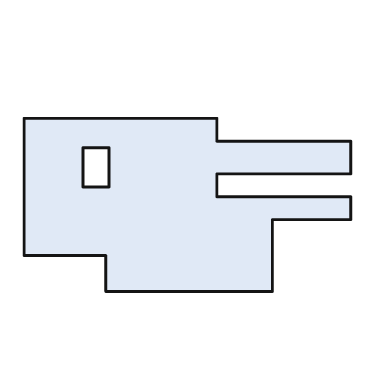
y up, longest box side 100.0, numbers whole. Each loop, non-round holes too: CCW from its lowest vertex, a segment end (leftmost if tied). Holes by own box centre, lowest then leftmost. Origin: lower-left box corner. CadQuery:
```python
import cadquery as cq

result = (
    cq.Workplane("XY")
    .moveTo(25.0, 0.0)
    .lineTo(76.0, 0.0)
    .lineTo(76.0, 22.0)
    .lineTo(100.0, 22.0)
    .lineTo(100.0, 29.0)
    .lineTo(59.0, 29.0)
    .lineTo(59.0, 36.0)
    .lineTo(100.0, 36.0)
    .lineTo(100.0, 46.0)
    .lineTo(59.0, 46.0)
    .lineTo(59.0, 53.0)
    .lineTo(0.0, 53.0)
    .lineTo(0.0, 11.0)
    .lineTo(25.0, 11.0)
    .close()
    .moveTo(18.0, 32.0)
    .lineTo(26.0, 32.0)
    .lineTo(26.0, 44.0)
    .lineTo(18.0, 44.0)
    .close()
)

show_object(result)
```